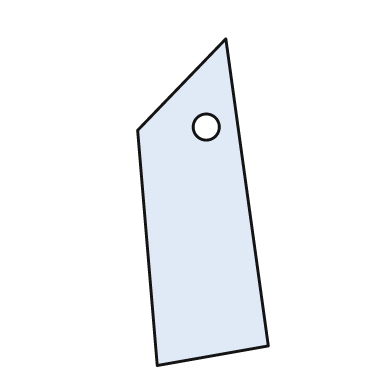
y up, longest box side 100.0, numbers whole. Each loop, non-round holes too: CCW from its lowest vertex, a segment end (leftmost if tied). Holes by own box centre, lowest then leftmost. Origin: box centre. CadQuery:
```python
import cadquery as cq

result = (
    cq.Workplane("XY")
    .moveTo(-14.0, -50.0)
    .lineTo(20.0, -44.0)
    .lineTo(7.0, 50.0)
    .lineTo(-20.0, 22.0)
    .close()
    .moveTo(1.0, 23.0)
    .circle(4.0)
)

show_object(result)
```